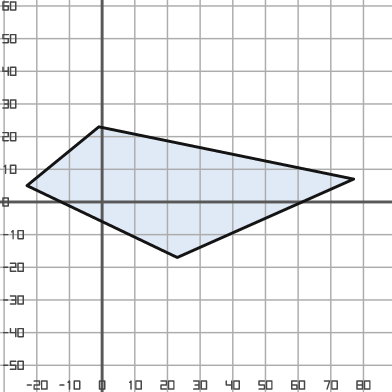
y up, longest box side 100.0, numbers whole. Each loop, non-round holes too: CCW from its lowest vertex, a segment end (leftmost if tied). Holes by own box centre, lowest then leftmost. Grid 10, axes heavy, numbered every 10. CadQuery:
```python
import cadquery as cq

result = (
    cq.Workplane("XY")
    .moveTo(23.0, -17.0)
    .lineTo(77.0, 7.0)
    .lineTo(-1.0, 23.0)
    .lineTo(-23.0, 5.0)
    .close()
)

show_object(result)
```